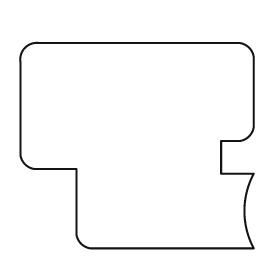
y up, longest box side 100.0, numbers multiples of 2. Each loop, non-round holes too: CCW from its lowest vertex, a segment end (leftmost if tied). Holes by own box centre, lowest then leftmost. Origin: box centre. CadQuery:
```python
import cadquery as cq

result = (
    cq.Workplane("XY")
    .moveTo(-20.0, -44.0)
    .lineTo(50.0, -44.0)
    .threePointArc((46.0, -28.0), (50.0, -12.0))
    .lineTo(36.0, -12.0)
    .lineTo(36.0, 2.0)
    .lineTo(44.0, 2.0)
    .threePointArc((48.0, 4.0), (50.0, 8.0))
    .lineTo(50.0, 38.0)
    .threePointArc((48.0, 42.0), (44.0, 44.0))
    .lineTo(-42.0, 44.0)
    .threePointArc((-48.0, 42.0), (-50.0, 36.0))
    .lineTo(-50.0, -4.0)
    .threePointArc((-48.0, -8.0), (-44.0, -10.0))
    .lineTo(-26.0, -10.0)
    .lineTo(-26.0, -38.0)
    .threePointArc((-24.0, -42.0), (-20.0, -44.0))
    .close()
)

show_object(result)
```